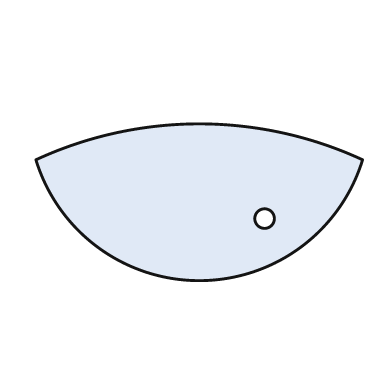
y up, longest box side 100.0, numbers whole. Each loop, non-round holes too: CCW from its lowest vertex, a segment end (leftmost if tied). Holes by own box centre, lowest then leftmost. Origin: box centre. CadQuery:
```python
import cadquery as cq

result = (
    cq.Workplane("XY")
    .moveTo(-50.0, 13.0)
    .threePointArc((0.0, -24.0), (50.0, 13.0))
    .threePointArc((0.0, 24.0), (-50.0, 13.0))
    .close()
    .moveTo(20.0, -5.0)
    .circle(3.0)
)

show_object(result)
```